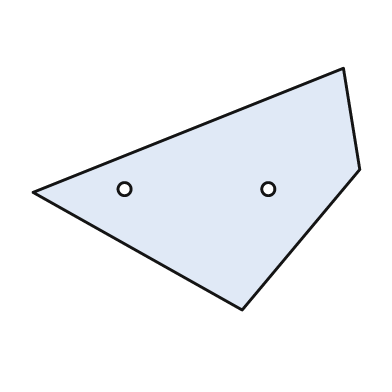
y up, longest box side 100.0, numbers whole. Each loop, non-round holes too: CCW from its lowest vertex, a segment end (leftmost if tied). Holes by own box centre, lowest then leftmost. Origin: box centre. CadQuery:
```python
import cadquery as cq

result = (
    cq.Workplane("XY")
    .moveTo(14.0, -37.0)
    .lineTo(50.0, 6.0)
    .lineTo(45.0, 37.0)
    .lineTo(-50.0, -1.0)
    .close()
    .moveTo(-22.0, 0.0)
    .circle(2.0)
    .moveTo(22.0, 0.0)
    .circle(2.0)
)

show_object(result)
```